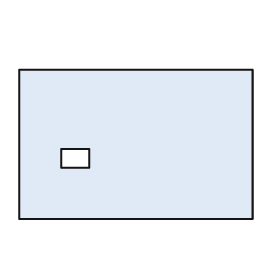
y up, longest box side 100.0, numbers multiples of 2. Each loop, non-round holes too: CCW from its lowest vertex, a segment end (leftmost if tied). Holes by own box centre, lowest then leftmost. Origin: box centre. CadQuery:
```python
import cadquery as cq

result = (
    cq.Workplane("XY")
    .moveTo(-50.0, -32.0)
    .lineTo(50.0, -32.0)
    .lineTo(50.0, 32.0)
    .lineTo(-50.0, 32.0)
    .close()
    .moveTo(-32.0, -10.0)
    .lineTo(-20.0, -10.0)
    .lineTo(-20.0, -2.0)
    .lineTo(-32.0, -2.0)
    .close()
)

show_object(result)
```